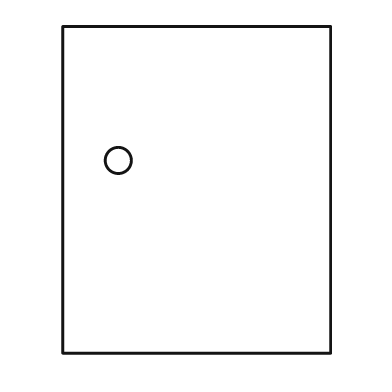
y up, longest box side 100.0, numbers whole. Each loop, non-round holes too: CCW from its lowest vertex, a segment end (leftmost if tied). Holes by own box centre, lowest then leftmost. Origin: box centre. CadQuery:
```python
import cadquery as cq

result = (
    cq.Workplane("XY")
    .moveTo(-41.0, -50.0)
    .lineTo(41.0, -50.0)
    .lineTo(41.0, 50.0)
    .lineTo(-41.0, 50.0)
    .close()
    .moveTo(-24.0, 9.0)
    .circle(4.0)
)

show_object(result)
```